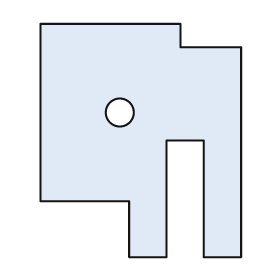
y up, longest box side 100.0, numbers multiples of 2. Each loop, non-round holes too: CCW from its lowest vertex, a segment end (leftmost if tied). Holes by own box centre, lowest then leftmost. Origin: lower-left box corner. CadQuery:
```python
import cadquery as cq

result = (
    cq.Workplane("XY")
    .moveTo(38.0, 0.0)
    .lineTo(54.0, 0.0)
    .lineTo(54.0, 50.0)
    .lineTo(70.0, 50.0)
    .lineTo(70.0, 0.0)
    .lineTo(86.0, 0.0)
    .lineTo(86.0, 90.0)
    .lineTo(60.0, 90.0)
    .lineTo(60.0, 100.0)
    .lineTo(0.0, 100.0)
    .lineTo(0.0, 24.0)
    .lineTo(38.0, 24.0)
    .close()
    .moveTo(34.0, 62.0)
    .circle(6.0)
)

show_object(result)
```